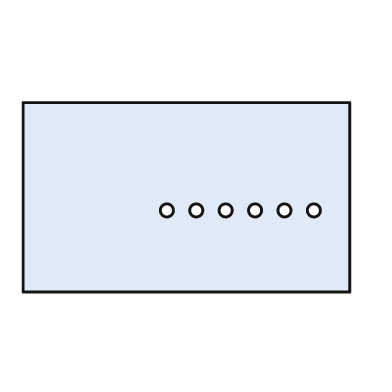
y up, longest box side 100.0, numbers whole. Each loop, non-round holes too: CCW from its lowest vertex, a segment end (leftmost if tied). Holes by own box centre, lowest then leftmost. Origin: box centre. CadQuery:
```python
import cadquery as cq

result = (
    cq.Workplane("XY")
    .moveTo(-50.0, -29.0)
    .lineTo(50.0, -29.0)
    .lineTo(50.0, 29.0)
    .lineTo(-50.0, 29.0)
    .close()
    .moveTo(-6.0, -4.0)
    .circle(2.0)
    .moveTo(3.0, -4.0)
    .circle(2.0)
    .moveTo(12.0, -4.0)
    .circle(2.0)
    .moveTo(21.0, -4.0)
    .circle(2.0)
    .moveTo(30.0, -4.0)
    .circle(2.0)
    .moveTo(39.0, -4.0)
    .circle(2.0)
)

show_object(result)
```